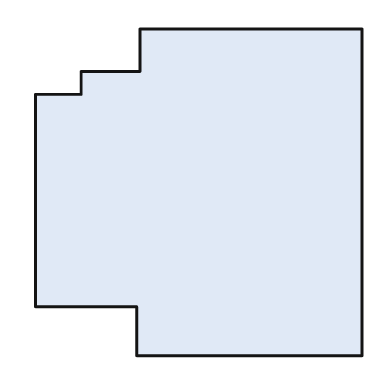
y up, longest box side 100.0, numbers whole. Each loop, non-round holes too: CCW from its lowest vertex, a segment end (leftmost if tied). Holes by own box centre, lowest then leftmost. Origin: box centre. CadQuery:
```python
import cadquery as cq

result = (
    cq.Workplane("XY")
    .moveTo(-19.0, -50.0)
    .lineTo(50.0, -50.0)
    .lineTo(50.0, 50.0)
    .lineTo(-18.0, 50.0)
    .lineTo(-18.0, 37.0)
    .lineTo(-36.0, 37.0)
    .lineTo(-36.0, 30.0)
    .lineTo(-50.0, 30.0)
    .lineTo(-50.0, -35.0)
    .lineTo(-19.0, -35.0)
    .close()
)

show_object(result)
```